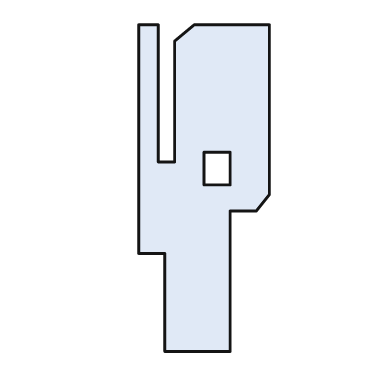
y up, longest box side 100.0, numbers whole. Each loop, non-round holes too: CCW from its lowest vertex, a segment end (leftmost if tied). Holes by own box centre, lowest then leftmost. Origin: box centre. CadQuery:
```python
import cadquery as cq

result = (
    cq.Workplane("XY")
    .moveTo(-12.0, -50.0)
    .lineTo(8.0, -50.0)
    .lineTo(8.0, -7.0)
    .lineTo(16.0, -7.0)
    .lineTo(20.0, -2.0)
    .lineTo(20.0, 50.0)
    .lineTo(-3.0, 50.0)
    .lineTo(-9.0, 45.0)
    .lineTo(-9.0, 8.0)
    .lineTo(-14.0, 8.0)
    .lineTo(-14.0, 50.0)
    .lineTo(-20.0, 50.0)
    .lineTo(-20.0, -20.0)
    .lineTo(-12.0, -20.0)
    .close()
    .moveTo(0.0, 1.0)
    .lineTo(8.0, 1.0)
    .lineTo(8.0, 11.0)
    .lineTo(0.0, 11.0)
    .close()
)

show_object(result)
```